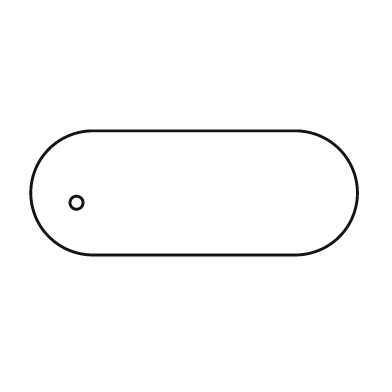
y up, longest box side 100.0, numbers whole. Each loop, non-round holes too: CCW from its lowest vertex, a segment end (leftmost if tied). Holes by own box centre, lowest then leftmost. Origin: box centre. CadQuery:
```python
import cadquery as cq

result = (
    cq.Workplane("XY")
    .moveTo(-31.0, -19.0)
    .lineTo(31.0, -19.0)
    .threePointArc((50.0, 0.0), (31.0, 19.0))
    .lineTo(-31.0, 19.0)
    .threePointArc((-50.0, 0.0), (-31.0, -19.0))
    .close()
    .moveTo(-36.0, -3.0)
    .circle(2.0)
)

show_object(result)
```